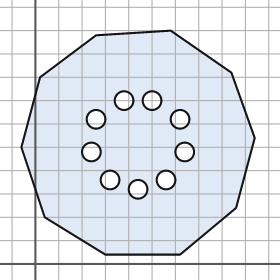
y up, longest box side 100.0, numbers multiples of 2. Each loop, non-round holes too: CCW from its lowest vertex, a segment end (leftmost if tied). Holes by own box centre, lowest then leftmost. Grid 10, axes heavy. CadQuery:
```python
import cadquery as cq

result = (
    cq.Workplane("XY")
    .moveTo(30.0, 4.0)
    .lineTo(62.0, 4.0)
    .lineTo(86.0, 24.0)
    .lineTo(94.0, 54.0)
    .lineTo(84.0, 82.0)
    .lineTo(58.0, 100.0)
    .lineTo(26.0, 98.0)
    .lineTo(2.0, 80.0)
    .lineTo(-6.0, 50.0)
    .lineTo(4.0, 20.0)
    .close()
    .moveTo(44.0, 32.0)
    .circle(4.0)
    .moveTo(32.0, 36.0)
    .circle(4.0)
    .moveTo(56.0, 36.0)
    .circle(4.0)
    .moveTo(24.0, 48.0)
    .circle(4.0)
    .moveTo(64.0, 48.0)
    .circle(4.0)
    .moveTo(26.0, 62.0)
    .circle(4.0)
    .moveTo(62.0, 62.0)
    .circle(4.0)
    .moveTo(38.0, 70.0)
    .circle(4.0)
    .moveTo(50.0, 70.0)
    .circle(4.0)
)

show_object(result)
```